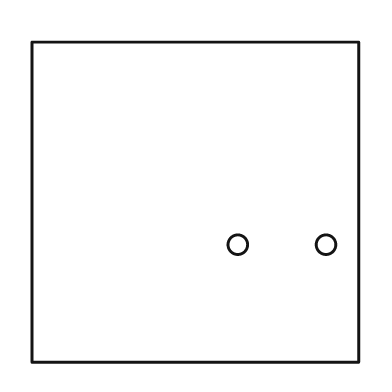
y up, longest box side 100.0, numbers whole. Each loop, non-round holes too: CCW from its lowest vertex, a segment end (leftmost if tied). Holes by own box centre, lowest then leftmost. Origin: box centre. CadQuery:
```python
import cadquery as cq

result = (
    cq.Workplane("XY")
    .moveTo(-50.0, -49.0)
    .lineTo(50.0, -49.0)
    .lineTo(50.0, 49.0)
    .lineTo(-50.0, 49.0)
    .close()
    .moveTo(13.0, -13.0)
    .circle(3.0)
    .moveTo(40.0, -13.0)
    .circle(3.0)
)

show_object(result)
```